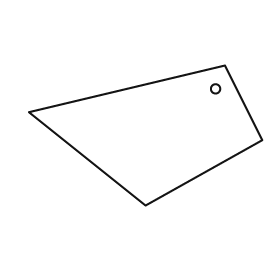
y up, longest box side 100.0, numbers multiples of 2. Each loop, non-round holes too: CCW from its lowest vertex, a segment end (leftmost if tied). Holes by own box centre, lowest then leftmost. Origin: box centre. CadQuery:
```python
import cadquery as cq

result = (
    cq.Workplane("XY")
    .moveTo(0.0, -30.0)
    .lineTo(50.0, -2.0)
    .lineTo(34.0, 30.0)
    .lineTo(-50.0, 10.0)
    .close()
    .moveTo(30.0, 20.0)
    .circle(2.0)
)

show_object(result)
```